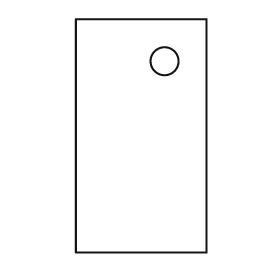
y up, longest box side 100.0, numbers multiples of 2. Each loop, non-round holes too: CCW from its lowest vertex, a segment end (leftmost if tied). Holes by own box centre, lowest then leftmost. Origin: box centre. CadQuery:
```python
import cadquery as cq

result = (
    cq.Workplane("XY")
    .moveTo(-28.0, -50.0)
    .lineTo(28.0, -50.0)
    .lineTo(28.0, 50.0)
    .lineTo(-28.0, 50.0)
    .close()
    .moveTo(10.0, 32.0)
    .circle(6.0)
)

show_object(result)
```